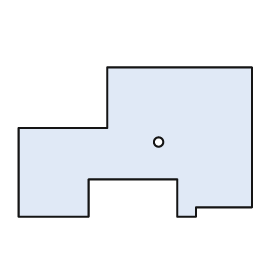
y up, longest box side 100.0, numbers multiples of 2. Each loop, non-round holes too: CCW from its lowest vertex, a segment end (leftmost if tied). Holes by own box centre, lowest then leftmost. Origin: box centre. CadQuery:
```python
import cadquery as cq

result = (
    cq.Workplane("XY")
    .moveTo(-50.0, -32.0)
    .lineTo(-20.0, -32.0)
    .lineTo(-20.0, -16.0)
    .lineTo(18.0, -16.0)
    .lineTo(18.0, -32.0)
    .lineTo(26.0, -32.0)
    .lineTo(26.0, -28.0)
    .lineTo(50.0, -28.0)
    .lineTo(50.0, 32.0)
    .lineTo(-12.0, 32.0)
    .lineTo(-12.0, 6.0)
    .lineTo(-50.0, 6.0)
    .close()
    .moveTo(10.0, 0.0)
    .circle(2.0)
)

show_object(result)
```